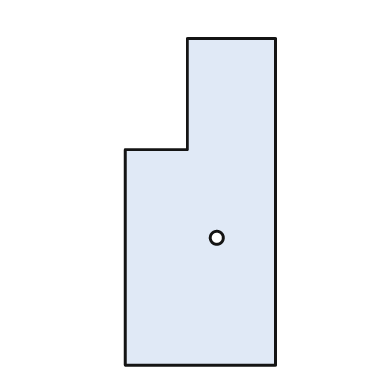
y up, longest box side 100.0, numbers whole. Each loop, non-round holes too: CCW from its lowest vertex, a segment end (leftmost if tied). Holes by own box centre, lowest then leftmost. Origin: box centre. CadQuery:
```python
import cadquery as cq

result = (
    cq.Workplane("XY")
    .moveTo(-23.0, -50.0)
    .lineTo(23.0, -50.0)
    .lineTo(23.0, 50.0)
    .lineTo(-4.0, 50.0)
    .lineTo(-4.0, 16.0)
    .lineTo(-23.0, 16.0)
    .close()
    .moveTo(5.0, -11.0)
    .circle(2.0)
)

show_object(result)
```